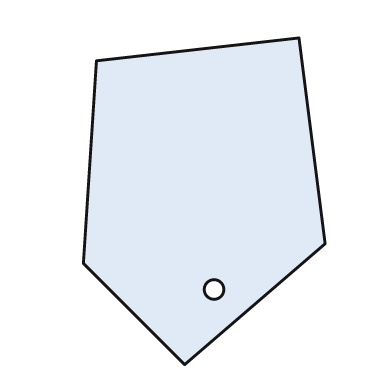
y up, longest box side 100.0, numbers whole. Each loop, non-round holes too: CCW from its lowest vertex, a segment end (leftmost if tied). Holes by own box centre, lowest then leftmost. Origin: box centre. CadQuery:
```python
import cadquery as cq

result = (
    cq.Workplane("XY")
    .moveTo(-6.0, -50.0)
    .lineTo(37.0, -13.0)
    .lineTo(29.0, 50.0)
    .lineTo(-33.0, 43.0)
    .lineTo(-37.0, -19.0)
    .close()
    .moveTo(3.0, -27.0)
    .circle(3.0)
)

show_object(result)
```